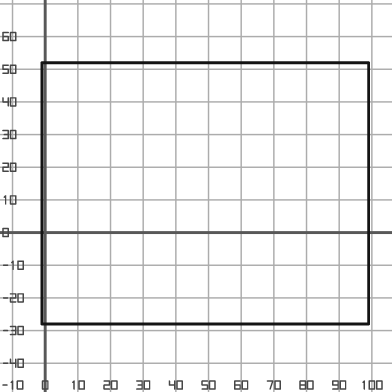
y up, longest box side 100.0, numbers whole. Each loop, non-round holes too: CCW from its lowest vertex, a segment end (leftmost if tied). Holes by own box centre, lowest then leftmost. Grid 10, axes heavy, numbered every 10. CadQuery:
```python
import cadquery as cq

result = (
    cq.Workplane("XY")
    .moveTo(-1.0, -28.0)
    .lineTo(99.0, -28.0)
    .lineTo(99.0, 52.0)
    .lineTo(-1.0, 52.0)
    .close()
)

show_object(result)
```